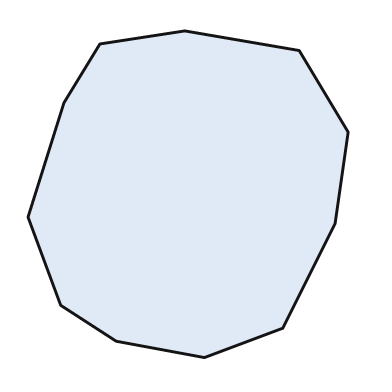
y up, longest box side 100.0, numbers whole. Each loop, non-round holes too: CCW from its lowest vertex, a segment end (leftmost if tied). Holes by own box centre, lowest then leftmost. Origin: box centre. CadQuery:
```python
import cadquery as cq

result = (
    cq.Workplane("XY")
    .moveTo(5.0, -50.0)
    .lineTo(29.0, -41.0)
    .lineTo(45.0, -9.0)
    .lineTo(49.0, 19.0)
    .lineTo(34.0, 44.0)
    .lineTo(-1.0, 50.0)
    .lineTo(-27.0, 46.0)
    .lineTo(-38.0, 28.0)
    .lineTo(-49.0, -7.0)
    .lineTo(-39.0, -34.0)
    .lineTo(-22.0, -45.0)
    .close()
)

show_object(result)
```